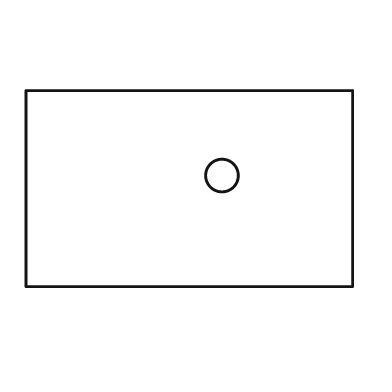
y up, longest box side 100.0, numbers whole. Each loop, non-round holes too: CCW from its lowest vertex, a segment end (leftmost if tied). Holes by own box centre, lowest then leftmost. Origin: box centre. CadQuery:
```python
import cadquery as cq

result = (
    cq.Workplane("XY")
    .moveTo(-50.0, -30.0)
    .lineTo(50.0, -30.0)
    .lineTo(50.0, 30.0)
    .lineTo(-50.0, 30.0)
    .close()
    .moveTo(10.0, 4.0)
    .circle(5.0)
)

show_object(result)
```